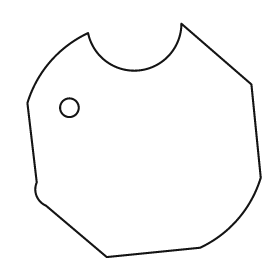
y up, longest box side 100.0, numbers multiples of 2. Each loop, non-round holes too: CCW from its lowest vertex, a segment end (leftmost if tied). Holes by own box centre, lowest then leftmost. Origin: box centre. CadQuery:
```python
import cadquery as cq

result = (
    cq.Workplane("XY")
    .moveTo(-16.0, -50.0)
    .lineTo(24.0, -46.0)
    .threePointArc((40.0, -34.0), (50.0, -16.0))
    .lineTo(46.0, 24.0)
    .lineTo(16.0, 50.0)
    .threePointArc((-2.0, 30.0), (-24.0, 46.0))
    .threePointArc((-40.0, 34.0), (-50.0, 16.0))
    .lineTo(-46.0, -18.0)
    .threePointArc((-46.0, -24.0), (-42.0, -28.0))
    .close()
    .moveTo(-32.0, 14.0)
    .circle(4.0)
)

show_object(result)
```